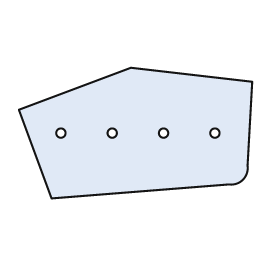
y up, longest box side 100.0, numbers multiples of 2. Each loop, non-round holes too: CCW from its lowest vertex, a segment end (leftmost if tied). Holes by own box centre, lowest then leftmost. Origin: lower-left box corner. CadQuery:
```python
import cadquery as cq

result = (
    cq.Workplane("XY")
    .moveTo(14.0, 0.0)
    .lineTo(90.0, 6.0)
    .threePointArc((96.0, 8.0), (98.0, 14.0))
    .lineTo(100.0, 50.0)
    .lineTo(48.0, 56.0)
    .lineTo(0.0, 38.0)
    .close()
    .moveTo(18.0, 28.0)
    .circle(2.0)
    .moveTo(40.0, 28.0)
    .circle(2.0)
    .moveTo(62.0, 28.0)
    .circle(2.0)
    .moveTo(84.0, 28.0)
    .circle(2.0)
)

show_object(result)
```